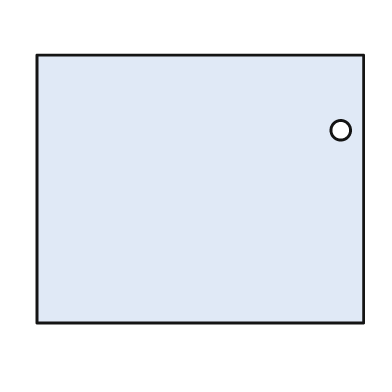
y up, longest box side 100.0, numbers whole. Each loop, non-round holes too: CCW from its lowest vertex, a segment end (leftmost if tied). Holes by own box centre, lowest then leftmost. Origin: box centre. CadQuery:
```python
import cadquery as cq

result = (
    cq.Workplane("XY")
    .moveTo(-50.0, -41.0)
    .lineTo(50.0, -41.0)
    .lineTo(50.0, 41.0)
    .lineTo(-50.0, 41.0)
    .close()
    .moveTo(43.0, 18.0)
    .circle(3.0)
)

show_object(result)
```